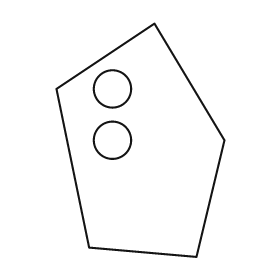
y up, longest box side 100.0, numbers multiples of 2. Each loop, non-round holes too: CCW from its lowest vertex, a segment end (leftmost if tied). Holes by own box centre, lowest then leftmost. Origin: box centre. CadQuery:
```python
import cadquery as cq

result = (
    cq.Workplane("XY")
    .moveTo(24.0, -50.0)
    .lineTo(36.0, 0.0)
    .lineTo(6.0, 50.0)
    .lineTo(-36.0, 22.0)
    .lineTo(-22.0, -46.0)
    .close()
    .moveTo(-12.0, 0.0)
    .circle(8.0)
    .moveTo(-12.0, 22.0)
    .circle(8.0)
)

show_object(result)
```